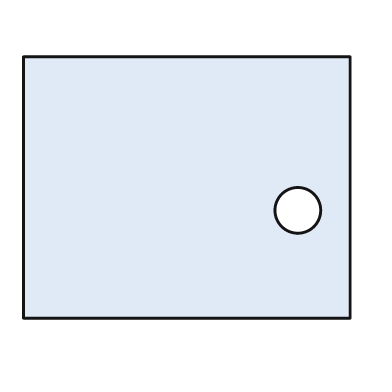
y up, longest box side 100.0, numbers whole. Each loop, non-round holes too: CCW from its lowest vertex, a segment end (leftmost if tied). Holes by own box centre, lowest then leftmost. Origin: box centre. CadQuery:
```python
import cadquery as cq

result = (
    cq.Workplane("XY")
    .moveTo(-50.0, -40.0)
    .lineTo(50.0, -40.0)
    .lineTo(50.0, 40.0)
    .lineTo(-50.0, 40.0)
    .close()
    .moveTo(34.0, -7.0)
    .circle(7.0)
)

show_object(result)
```